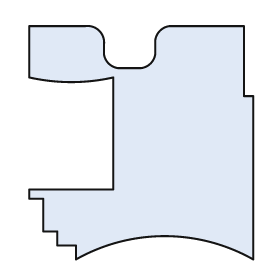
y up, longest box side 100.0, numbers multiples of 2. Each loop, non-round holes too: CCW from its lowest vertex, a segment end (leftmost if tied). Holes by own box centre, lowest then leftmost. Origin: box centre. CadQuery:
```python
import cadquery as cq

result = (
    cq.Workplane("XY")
    .moveTo(-28.0, -50.0)
    .threePointArc((10.0, -40.0), (48.0, -50.0))
    .lineTo(48.0, 20.0)
    .lineTo(44.0, 20.0)
    .lineTo(44.0, 50.0)
    .lineTo(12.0, 50.0)
    .threePointArc((8.0, 48.0), (6.0, 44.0))
    .lineTo(6.0, 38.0)
    .threePointArc((4.0, 34.0), (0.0, 32.0))
    .lineTo(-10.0, 32.0)
    .threePointArc((-14.0, 34.0), (-16.0, 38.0))
    .lineTo(-16.0, 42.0)
    .threePointArc((-18.0, 48.0), (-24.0, 50.0))
    .lineTo(-48.0, 50.0)
    .lineTo(-48.0, 28.0)
    .threePointArc((-30.0, 26.0), (-12.0, 28.0))
    .lineTo(-12.0, -20.0)
    .lineTo(-48.0, -20.0)
    .lineTo(-48.0, -24.0)
    .lineTo(-42.0, -24.0)
    .lineTo(-42.0, -38.0)
    .lineTo(-36.0, -38.0)
    .lineTo(-36.0, -44.0)
    .lineTo(-28.0, -44.0)
    .close()
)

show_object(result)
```